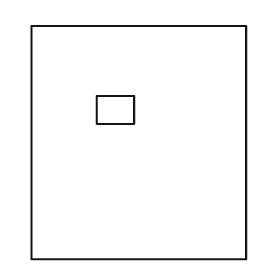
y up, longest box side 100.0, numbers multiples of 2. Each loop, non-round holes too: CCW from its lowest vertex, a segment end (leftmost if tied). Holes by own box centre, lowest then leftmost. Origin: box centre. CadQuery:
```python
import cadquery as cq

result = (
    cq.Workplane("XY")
    .moveTo(-46.0, -50.0)
    .lineTo(46.0, -50.0)
    .lineTo(46.0, 50.0)
    .lineTo(-46.0, 50.0)
    .close()
    .moveTo(-18.0, 8.0)
    .lineTo(-2.0, 8.0)
    .lineTo(-2.0, 20.0)
    .lineTo(-18.0, 20.0)
    .close()
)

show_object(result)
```